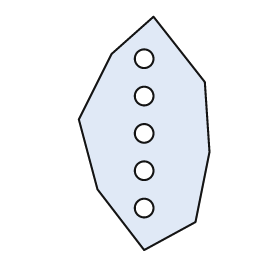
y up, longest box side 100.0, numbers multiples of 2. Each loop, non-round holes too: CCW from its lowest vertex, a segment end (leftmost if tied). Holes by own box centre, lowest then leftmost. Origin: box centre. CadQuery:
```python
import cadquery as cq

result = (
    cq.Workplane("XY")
    .moveTo(0.0, -50.0)
    .lineTo(22.0, -38.0)
    .lineTo(28.0, -8.0)
    .lineTo(26.0, 22.0)
    .lineTo(4.0, 50.0)
    .lineTo(-14.0, 34.0)
    .lineTo(-28.0, 6.0)
    .lineTo(-20.0, -24.0)
    .close()
    .moveTo(0.0, -32.0)
    .circle(4.0)
    .moveTo(0.0, -16.0)
    .circle(4.0)
    .moveTo(0.0, 0.0)
    .circle(4.0)
    .moveTo(0.0, 16.0)
    .circle(4.0)
    .moveTo(0.0, 32.0)
    .circle(4.0)
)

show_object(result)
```